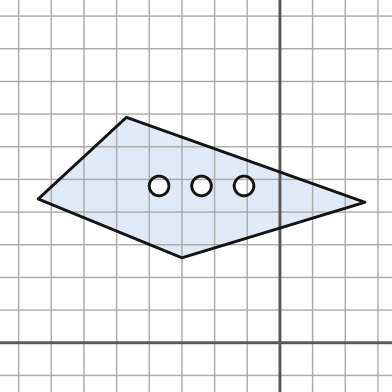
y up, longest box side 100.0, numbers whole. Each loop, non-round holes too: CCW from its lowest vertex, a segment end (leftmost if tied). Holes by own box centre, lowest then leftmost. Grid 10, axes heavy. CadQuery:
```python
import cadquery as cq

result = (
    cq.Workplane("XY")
    .moveTo(-30.0, 26.0)
    .lineTo(26.0, 43.0)
    .lineTo(-47.0, 69.0)
    .lineTo(-74.0, 44.0)
    .close()
    .moveTo(-37.0, 48.0)
    .circle(3.0)
    .moveTo(-24.0, 48.0)
    .circle(3.0)
    .moveTo(-11.0, 48.0)
    .circle(3.0)
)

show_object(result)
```